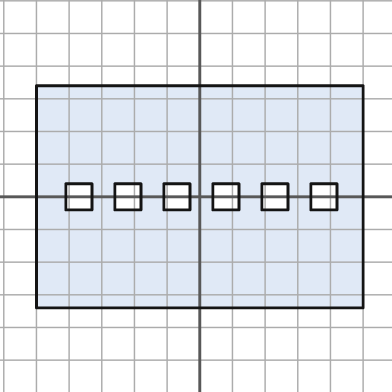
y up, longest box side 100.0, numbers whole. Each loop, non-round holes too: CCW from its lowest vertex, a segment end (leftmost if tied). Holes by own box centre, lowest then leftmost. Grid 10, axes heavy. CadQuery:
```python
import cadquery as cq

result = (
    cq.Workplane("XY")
    .moveTo(-50.0, -34.0)
    .lineTo(50.0, -34.0)
    .lineTo(50.0, 34.0)
    .lineTo(-50.0, 34.0)
    .close()
    .moveTo(-41.0, -4.0)
    .lineTo(-33.0, -4.0)
    .lineTo(-33.0, 4.0)
    .lineTo(-41.0, 4.0)
    .close()
    .moveTo(-26.0, -4.0)
    .lineTo(-18.0, -4.0)
    .lineTo(-18.0, 4.0)
    .lineTo(-26.0, 4.0)
    .close()
    .moveTo(-11.0, -4.0)
    .lineTo(-3.0, -4.0)
    .lineTo(-3.0, 4.0)
    .lineTo(-11.0, 4.0)
    .close()
    .moveTo(4.0, -4.0)
    .lineTo(12.0, -4.0)
    .lineTo(12.0, 4.0)
    .lineTo(4.0, 4.0)
    .close()
    .moveTo(19.0, -4.0)
    .lineTo(27.0, -4.0)
    .lineTo(27.0, 4.0)
    .lineTo(19.0, 4.0)
    .close()
    .moveTo(34.0, -4.0)
    .lineTo(42.0, -4.0)
    .lineTo(42.0, 4.0)
    .lineTo(34.0, 4.0)
    .close()
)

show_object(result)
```